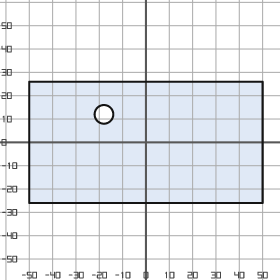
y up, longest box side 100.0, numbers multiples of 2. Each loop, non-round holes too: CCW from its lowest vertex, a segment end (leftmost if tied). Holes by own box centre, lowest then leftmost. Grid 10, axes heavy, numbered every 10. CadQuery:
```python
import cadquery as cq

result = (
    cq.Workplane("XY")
    .moveTo(-50.0, -26.0)
    .lineTo(50.0, -26.0)
    .lineTo(50.0, 26.0)
    .lineTo(-50.0, 26.0)
    .close()
    .moveTo(-18.0, 12.0)
    .circle(4.0)
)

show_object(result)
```